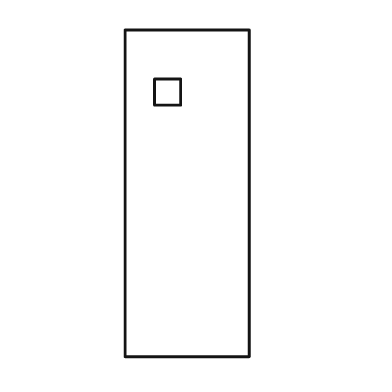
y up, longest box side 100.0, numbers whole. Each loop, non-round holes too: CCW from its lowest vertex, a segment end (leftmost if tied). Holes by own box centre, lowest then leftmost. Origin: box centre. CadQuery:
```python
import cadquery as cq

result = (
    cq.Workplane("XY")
    .moveTo(-19.0, -50.0)
    .lineTo(19.0, -50.0)
    .lineTo(19.0, 50.0)
    .lineTo(-19.0, 50.0)
    .close()
    .moveTo(-10.0, 27.0)
    .lineTo(-2.0, 27.0)
    .lineTo(-2.0, 35.0)
    .lineTo(-10.0, 35.0)
    .close()
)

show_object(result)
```